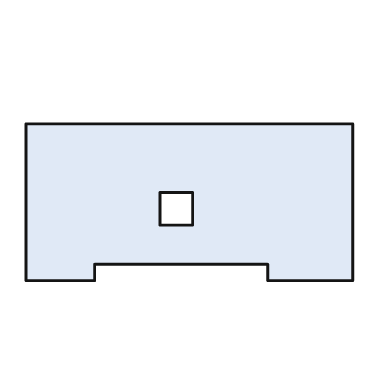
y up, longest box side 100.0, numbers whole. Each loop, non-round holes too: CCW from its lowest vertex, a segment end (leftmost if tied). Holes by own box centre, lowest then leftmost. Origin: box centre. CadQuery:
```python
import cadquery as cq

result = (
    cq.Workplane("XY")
    .moveTo(-50.0, -24.0)
    .lineTo(-29.0, -24.0)
    .lineTo(-29.0, -19.0)
    .lineTo(24.0, -19.0)
    .lineTo(24.0, -24.0)
    .lineTo(50.0, -24.0)
    .lineTo(50.0, 24.0)
    .lineTo(-50.0, 24.0)
    .close()
    .moveTo(-9.0, -7.0)
    .lineTo(1.0, -7.0)
    .lineTo(1.0, 3.0)
    .lineTo(-9.0, 3.0)
    .close()
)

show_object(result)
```